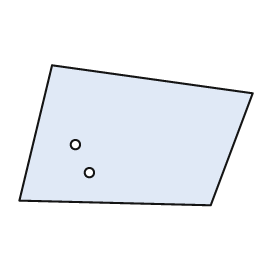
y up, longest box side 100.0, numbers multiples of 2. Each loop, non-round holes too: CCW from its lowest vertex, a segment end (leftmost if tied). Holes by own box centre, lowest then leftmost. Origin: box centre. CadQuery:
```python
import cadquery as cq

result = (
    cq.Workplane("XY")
    .moveTo(32.0, -30.0)
    .lineTo(50.0, 18.0)
    .lineTo(-36.0, 30.0)
    .lineTo(-50.0, -28.0)
    .close()
    .moveTo(-20.0, -16.0)
    .circle(2.0)
    .moveTo(-26.0, -4.0)
    .circle(2.0)
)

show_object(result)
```